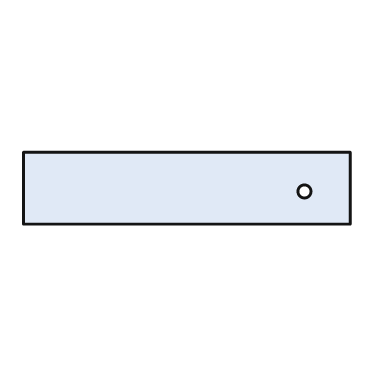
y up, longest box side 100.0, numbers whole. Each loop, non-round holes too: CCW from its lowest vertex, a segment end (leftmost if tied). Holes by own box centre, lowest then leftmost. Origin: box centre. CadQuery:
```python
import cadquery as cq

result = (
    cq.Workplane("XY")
    .moveTo(-50.0, -11.0)
    .lineTo(50.0, -11.0)
    .lineTo(50.0, 11.0)
    .lineTo(-50.0, 11.0)
    .close()
    .moveTo(36.0, -1.0)
    .circle(2.0)
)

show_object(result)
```